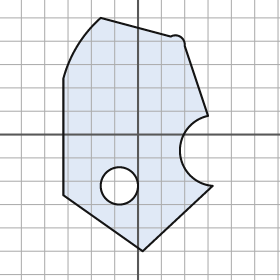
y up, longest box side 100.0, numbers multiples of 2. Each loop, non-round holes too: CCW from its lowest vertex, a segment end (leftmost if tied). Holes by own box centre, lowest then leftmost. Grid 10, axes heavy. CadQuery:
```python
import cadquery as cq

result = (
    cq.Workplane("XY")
    .moveTo(2.0, -50.0)
    .lineTo(32.0, -22.0)
    .threePointArc((18.0, -8.0), (30.0, 8.0))
    .lineTo(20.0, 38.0)
    .threePointArc((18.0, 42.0), (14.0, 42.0))
    .lineTo(-16.0, 50.0)
    .threePointArc((-26.0, 38.0), (-32.0, 24.0))
    .lineTo(-32.0, -26.0)
    .close()
    .moveTo(-8.0, -22.0)
    .circle(8.0)
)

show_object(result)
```